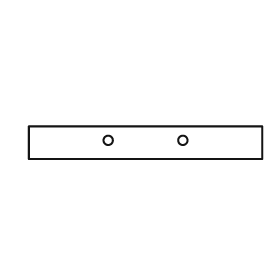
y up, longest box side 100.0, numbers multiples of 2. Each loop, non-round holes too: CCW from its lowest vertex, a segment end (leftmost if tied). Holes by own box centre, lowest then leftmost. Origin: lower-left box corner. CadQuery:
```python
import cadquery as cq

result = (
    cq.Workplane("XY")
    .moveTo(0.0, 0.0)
    .lineTo(100.0, 0.0)
    .lineTo(100.0, 14.0)
    .lineTo(0.0, 14.0)
    .close()
    .moveTo(34.0, 8.0)
    .circle(2.0)
    .moveTo(66.0, 8.0)
    .circle(2.0)
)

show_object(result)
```